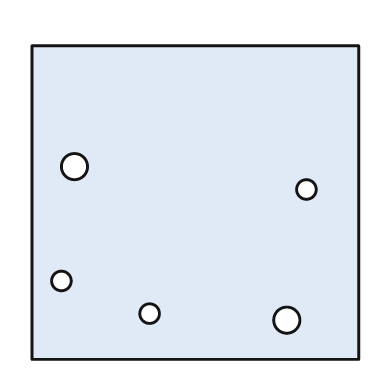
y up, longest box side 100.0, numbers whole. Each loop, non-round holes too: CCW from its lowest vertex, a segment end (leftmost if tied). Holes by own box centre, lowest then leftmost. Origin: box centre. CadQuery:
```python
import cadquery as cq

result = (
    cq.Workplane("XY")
    .moveTo(-50.0, -48.0)
    .lineTo(50.0, -48.0)
    .lineTo(50.0, 48.0)
    .lineTo(-50.0, 48.0)
    .close()
    .moveTo(28.0, -36.0)
    .circle(4.0)
    .moveTo(-14.0, -34.0)
    .circle(3.0)
    .moveTo(-41.0, -24.0)
    .circle(3.0)
    .moveTo(34.0, 4.0)
    .circle(3.0)
    .moveTo(-37.0, 11.0)
    .circle(4.0)
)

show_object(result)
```